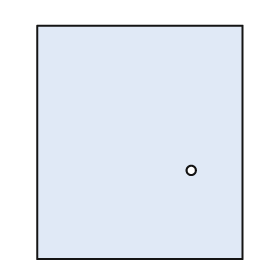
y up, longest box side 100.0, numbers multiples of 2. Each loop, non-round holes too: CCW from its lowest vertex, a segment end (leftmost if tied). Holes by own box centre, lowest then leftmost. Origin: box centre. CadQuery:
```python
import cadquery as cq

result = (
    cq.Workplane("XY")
    .moveTo(-44.0, -50.0)
    .lineTo(44.0, -50.0)
    .lineTo(44.0, 50.0)
    .lineTo(-44.0, 50.0)
    .close()
    .moveTo(22.0, -12.0)
    .circle(2.0)
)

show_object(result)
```